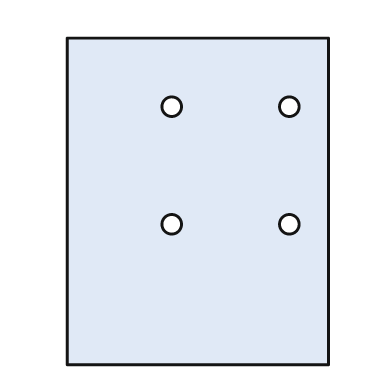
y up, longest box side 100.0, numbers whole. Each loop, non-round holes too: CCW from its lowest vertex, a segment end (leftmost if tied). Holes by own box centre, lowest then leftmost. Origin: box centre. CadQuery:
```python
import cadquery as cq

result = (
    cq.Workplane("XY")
    .moveTo(-40.0, -50.0)
    .lineTo(40.0, -50.0)
    .lineTo(40.0, 50.0)
    .lineTo(-40.0, 50.0)
    .close()
    .moveTo(-8.0, -7.0)
    .circle(3.0)
    .moveTo(28.0, -7.0)
    .circle(3.0)
    .moveTo(-8.0, 29.0)
    .circle(3.0)
    .moveTo(28.0, 29.0)
    .circle(3.0)
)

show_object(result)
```